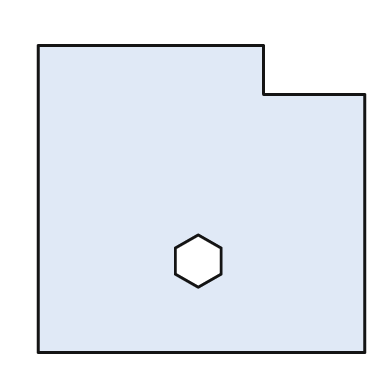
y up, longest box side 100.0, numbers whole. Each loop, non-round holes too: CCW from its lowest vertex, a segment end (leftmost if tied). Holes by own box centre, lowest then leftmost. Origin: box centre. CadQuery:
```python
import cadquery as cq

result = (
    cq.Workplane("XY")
    .moveTo(-50.0, -47.0)
    .lineTo(50.0, -47.0)
    .lineTo(50.0, 32.0)
    .lineTo(19.0, 32.0)
    .lineTo(19.0, 47.0)
    .lineTo(-50.0, 47.0)
    .close()
    .moveTo(-1.0, -27.0)
    .lineTo(6.0, -23.0)
    .lineTo(6.0, -15.0)
    .lineTo(-1.0, -11.0)
    .lineTo(-8.0, -15.0)
    .lineTo(-8.0, -23.0)
    .close()
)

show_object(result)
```